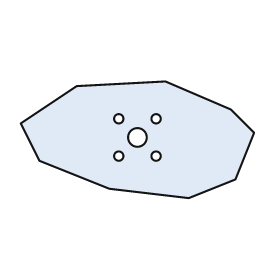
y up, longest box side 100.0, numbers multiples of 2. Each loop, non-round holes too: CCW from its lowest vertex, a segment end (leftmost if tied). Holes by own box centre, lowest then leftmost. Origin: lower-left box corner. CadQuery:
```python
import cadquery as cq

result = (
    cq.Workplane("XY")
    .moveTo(72.0, 0.0)
    .lineTo(92.0, 8.0)
    .lineTo(100.0, 28.0)
    .lineTo(90.0, 38.0)
    .lineTo(62.0, 50.0)
    .lineTo(24.0, 48.0)
    .lineTo(0.0, 32.0)
    .lineTo(8.0, 16.0)
    .lineTo(38.0, 4.0)
    .close()
    .moveTo(42.0, 18.0)
    .circle(2.0)
    .moveTo(58.0, 18.0)
    .circle(2.0)
    .moveTo(50.0, 26.0)
    .circle(4.0)
    .moveTo(42.0, 34.0)
    .circle(2.0)
    .moveTo(58.0, 34.0)
    .circle(2.0)
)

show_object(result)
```